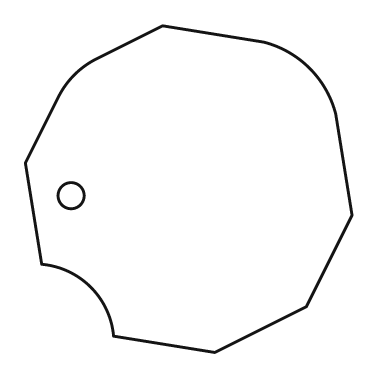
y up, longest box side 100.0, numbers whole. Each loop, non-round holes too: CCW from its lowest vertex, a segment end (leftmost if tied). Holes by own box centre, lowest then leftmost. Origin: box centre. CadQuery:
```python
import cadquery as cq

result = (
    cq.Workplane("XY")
    .moveTo(8.0, -50.0)
    .lineTo(36.0, -36.0)
    .lineTo(50.0, -8.0)
    .lineTo(45.0, 23.0)
    .threePointArc((37.0, 37.0), (23.0, 45.0))
    .lineTo(-8.0, 50.0)
    .lineTo(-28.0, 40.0)
    .threePointArc((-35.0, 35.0), (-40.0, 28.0))
    .lineTo(-50.0, 8.0)
    .lineTo(-45.0, -23.0)
    .threePointArc((-30.0, -30.0), (-23.0, -45.0))
    .close()
    .moveTo(-36.0, -2.0)
    .circle(4.0)
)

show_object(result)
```